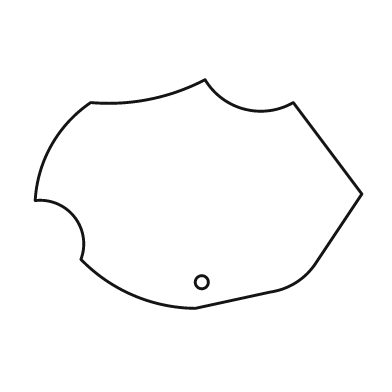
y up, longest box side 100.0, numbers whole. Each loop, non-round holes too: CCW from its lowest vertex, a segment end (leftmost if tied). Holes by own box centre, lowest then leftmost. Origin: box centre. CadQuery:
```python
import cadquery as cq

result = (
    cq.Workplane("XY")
    .moveTo(-1.0, -35.0)
    .lineTo(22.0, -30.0)
    .threePointArc((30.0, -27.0), (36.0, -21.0))
    .lineTo(50.0, 0.0)
    .lineTo(29.0, 28.0)
    .threePointArc((14.0, 26.0), (2.0, 35.0))
    .threePointArc((-15.0, 29.0), (-33.0, 28.0))
    .threePointArc((-45.0, 15.0), (-50.0, -2.0))
    .threePointArc((-38.0, -7.0), (-36.0, -20.0))
    .threePointArc((-20.0, -31.0), (-1.0, -35.0))
    .close()
    .moveTo(1.0, -27.0)
    .circle(2.0)
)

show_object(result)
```